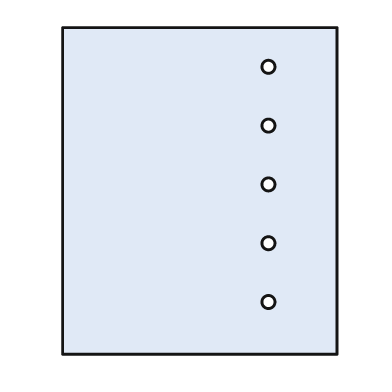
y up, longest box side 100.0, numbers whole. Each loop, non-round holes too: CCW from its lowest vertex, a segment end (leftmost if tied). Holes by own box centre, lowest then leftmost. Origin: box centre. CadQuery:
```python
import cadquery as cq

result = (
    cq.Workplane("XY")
    .moveTo(-42.0, -50.0)
    .lineTo(42.0, -50.0)
    .lineTo(42.0, 50.0)
    .lineTo(-42.0, 50.0)
    .close()
    .moveTo(21.0, -34.0)
    .circle(2.0)
    .moveTo(21.0, -16.0)
    .circle(2.0)
    .moveTo(21.0, 2.0)
    .circle(2.0)
    .moveTo(21.0, 20.0)
    .circle(2.0)
    .moveTo(21.0, 38.0)
    .circle(2.0)
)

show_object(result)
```